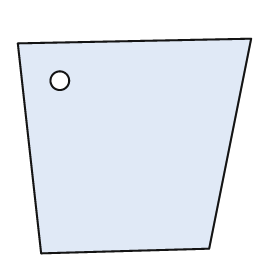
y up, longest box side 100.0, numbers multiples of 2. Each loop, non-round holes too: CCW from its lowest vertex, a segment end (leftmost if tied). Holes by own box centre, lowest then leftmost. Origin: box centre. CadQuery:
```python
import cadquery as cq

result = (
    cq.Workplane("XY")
    .moveTo(-40.0, -46.0)
    .lineTo(32.0, -44.0)
    .lineTo(50.0, 46.0)
    .lineTo(-50.0, 44.0)
    .close()
    .moveTo(-32.0, 28.0)
    .circle(4.0)
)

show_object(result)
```